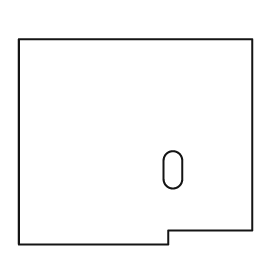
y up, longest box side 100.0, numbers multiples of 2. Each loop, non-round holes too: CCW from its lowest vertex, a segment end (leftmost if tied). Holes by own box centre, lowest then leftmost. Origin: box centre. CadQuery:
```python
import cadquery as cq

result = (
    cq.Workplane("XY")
    .moveTo(-50.0, -44.0)
    .lineTo(14.0, -44.0)
    .lineTo(14.0, -38.0)
    .lineTo(50.0, -38.0)
    .lineTo(50.0, 44.0)
    .lineTo(-50.0, 44.0)
    .close()
    .moveTo(12.0, -16.0)
    .threePointArc((16.0, -20.0), (20.0, -16.0))
    .lineTo(20.0, -8.0)
    .threePointArc((16.0, -4.0), (12.0, -8.0))
    .close()
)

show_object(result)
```